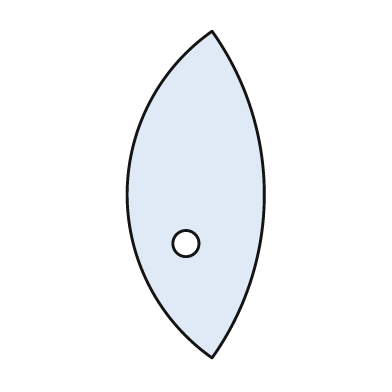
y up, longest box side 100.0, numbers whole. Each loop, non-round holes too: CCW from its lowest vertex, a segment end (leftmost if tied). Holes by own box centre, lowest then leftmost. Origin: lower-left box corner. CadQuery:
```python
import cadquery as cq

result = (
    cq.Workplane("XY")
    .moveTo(26.0, 0.0)
    .threePointArc((42.0, 50.0), (26.0, 100.0))
    .threePointArc((0.0, 50.0), (26.0, 0.0))
    .close()
    .moveTo(18.0, 35.0)
    .circle(4.0)
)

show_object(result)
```